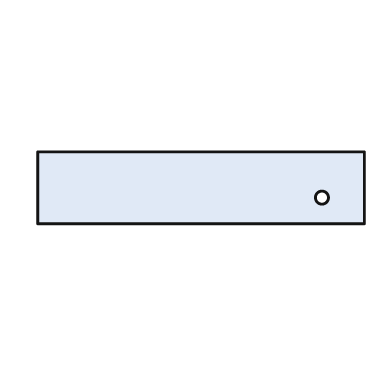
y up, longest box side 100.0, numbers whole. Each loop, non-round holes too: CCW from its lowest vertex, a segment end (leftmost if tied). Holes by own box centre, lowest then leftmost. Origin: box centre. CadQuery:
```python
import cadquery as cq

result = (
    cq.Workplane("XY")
    .moveTo(-50.0, -11.0)
    .lineTo(50.0, -11.0)
    .lineTo(50.0, 11.0)
    .lineTo(-50.0, 11.0)
    .close()
    .moveTo(37.0, -3.0)
    .circle(2.0)
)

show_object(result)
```